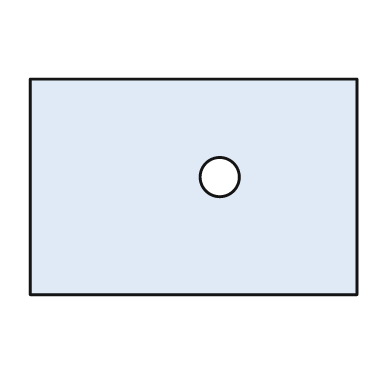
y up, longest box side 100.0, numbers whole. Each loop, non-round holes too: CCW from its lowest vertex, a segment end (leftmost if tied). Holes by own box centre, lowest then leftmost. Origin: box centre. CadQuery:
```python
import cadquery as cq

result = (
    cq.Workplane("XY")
    .moveTo(-50.0, -33.0)
    .lineTo(50.0, -33.0)
    .lineTo(50.0, 33.0)
    .lineTo(-50.0, 33.0)
    .close()
    .moveTo(8.0, 3.0)
    .circle(6.0)
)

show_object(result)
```